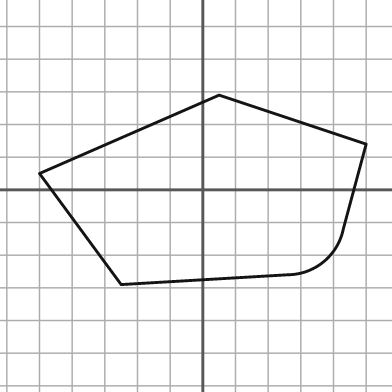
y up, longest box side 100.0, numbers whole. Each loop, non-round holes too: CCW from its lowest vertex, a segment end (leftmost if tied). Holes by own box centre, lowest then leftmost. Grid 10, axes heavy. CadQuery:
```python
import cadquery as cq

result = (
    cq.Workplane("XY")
    .moveTo(-25.0, -29.0)
    .lineTo(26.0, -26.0)
    .threePointArc((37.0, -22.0), (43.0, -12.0))
    .lineTo(50.0, 14.0)
    .lineTo(5.0, 29.0)
    .lineTo(-50.0, 5.0)
    .close()
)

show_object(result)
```